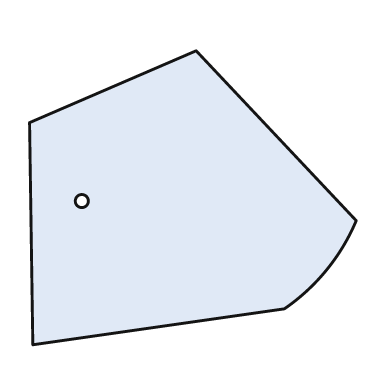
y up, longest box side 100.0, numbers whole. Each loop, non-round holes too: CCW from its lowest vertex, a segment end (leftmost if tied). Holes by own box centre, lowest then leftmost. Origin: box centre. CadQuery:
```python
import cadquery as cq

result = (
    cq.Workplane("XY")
    .moveTo(-49.0, -45.0)
    .lineTo(28.0, -34.0)
    .threePointArc((41.0, -22.0), (50.0, -7.0))
    .lineTo(1.0, 45.0)
    .lineTo(-50.0, 23.0)
    .close()
    .moveTo(-34.0, -1.0)
    .circle(2.0)
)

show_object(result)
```